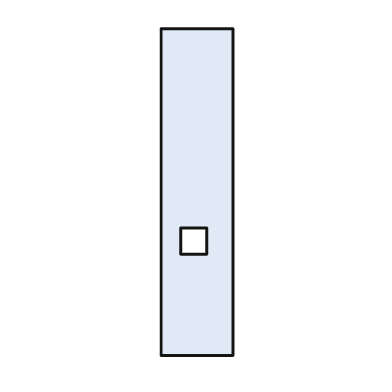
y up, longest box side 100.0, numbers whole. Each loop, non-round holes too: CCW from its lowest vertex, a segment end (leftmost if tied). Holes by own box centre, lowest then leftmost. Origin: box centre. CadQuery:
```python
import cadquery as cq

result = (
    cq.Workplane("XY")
    .moveTo(-11.0, -50.0)
    .lineTo(11.0, -50.0)
    .lineTo(11.0, 50.0)
    .lineTo(-11.0, 50.0)
    .close()
    .moveTo(-5.0, -19.0)
    .lineTo(3.0, -19.0)
    .lineTo(3.0, -11.0)
    .lineTo(-5.0, -11.0)
    .close()
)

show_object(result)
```